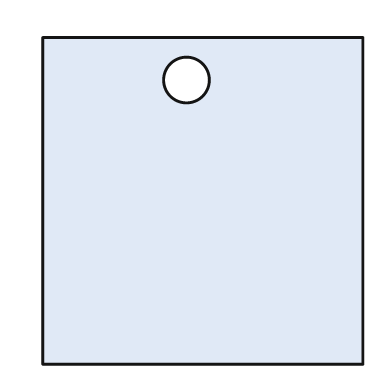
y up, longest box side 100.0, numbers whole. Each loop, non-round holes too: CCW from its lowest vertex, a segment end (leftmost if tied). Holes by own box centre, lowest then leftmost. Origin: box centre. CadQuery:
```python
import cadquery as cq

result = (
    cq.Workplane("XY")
    .moveTo(-49.0, -50.0)
    .lineTo(49.0, -50.0)
    .lineTo(49.0, 50.0)
    .lineTo(-49.0, 50.0)
    .close()
    .moveTo(-5.0, 37.0)
    .circle(7.0)
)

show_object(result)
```